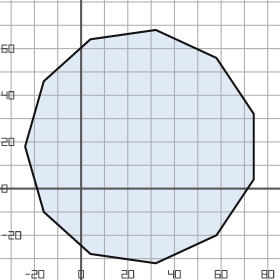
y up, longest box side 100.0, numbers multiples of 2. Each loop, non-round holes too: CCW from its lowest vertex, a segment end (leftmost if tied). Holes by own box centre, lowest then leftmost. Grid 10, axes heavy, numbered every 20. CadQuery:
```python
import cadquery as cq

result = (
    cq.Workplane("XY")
    .moveTo(32.0, -32.0)
    .lineTo(58.0, -20.0)
    .lineTo(74.0, 4.0)
    .lineTo(74.0, 32.0)
    .lineTo(58.0, 56.0)
    .lineTo(32.0, 68.0)
    .lineTo(4.0, 64.0)
    .lineTo(-16.0, 46.0)
    .lineTo(-24.0, 18.0)
    .lineTo(-16.0, -10.0)
    .lineTo(4.0, -28.0)
    .close()
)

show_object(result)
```